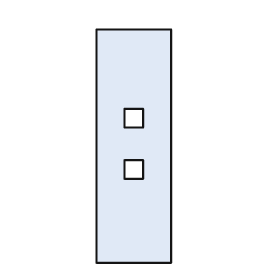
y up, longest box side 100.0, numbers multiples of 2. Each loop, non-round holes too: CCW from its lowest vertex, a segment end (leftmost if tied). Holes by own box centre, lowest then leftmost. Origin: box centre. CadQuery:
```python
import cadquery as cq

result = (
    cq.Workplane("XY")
    .moveTo(-16.0, -50.0)
    .lineTo(16.0, -50.0)
    .lineTo(16.0, 50.0)
    .lineTo(-16.0, 50.0)
    .close()
    .moveTo(-4.0, -14.0)
    .lineTo(4.0, -14.0)
    .lineTo(4.0, -6.0)
    .lineTo(-4.0, -6.0)
    .close()
    .moveTo(-4.0, 8.0)
    .lineTo(4.0, 8.0)
    .lineTo(4.0, 16.0)
    .lineTo(-4.0, 16.0)
    .close()
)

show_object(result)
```